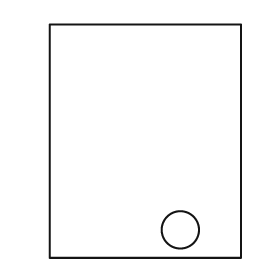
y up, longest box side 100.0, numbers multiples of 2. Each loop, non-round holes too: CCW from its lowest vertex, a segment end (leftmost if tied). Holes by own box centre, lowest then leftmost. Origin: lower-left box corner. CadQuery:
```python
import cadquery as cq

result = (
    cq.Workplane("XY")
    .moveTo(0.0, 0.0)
    .lineTo(82.0, 0.0)
    .lineTo(82.0, 100.0)
    .lineTo(0.0, 100.0)
    .close()
    .moveTo(56.0, 12.0)
    .circle(8.0)
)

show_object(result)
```